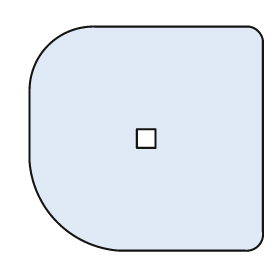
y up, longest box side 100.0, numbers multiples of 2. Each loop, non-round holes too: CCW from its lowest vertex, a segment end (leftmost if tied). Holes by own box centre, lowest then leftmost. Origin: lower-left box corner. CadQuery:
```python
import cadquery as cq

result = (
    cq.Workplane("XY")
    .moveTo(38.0, 0.0)
    .lineTo(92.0, 0.0)
    .threePointArc((98.0, 2.0), (100.0, 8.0))
    .lineTo(100.0, 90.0)
    .threePointArc((98.0, 94.0), (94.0, 96.0))
    .lineTo(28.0, 96.0)
    .threePointArc((8.0, 88.0), (0.0, 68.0))
    .lineTo(0.0, 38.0)
    .threePointArc((12.0, 12.0), (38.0, 0.0))
    .close()
    .moveTo(46.0, 44.0)
    .lineTo(54.0, 44.0)
    .lineTo(54.0, 52.0)
    .lineTo(46.0, 52.0)
    .close()
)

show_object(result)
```